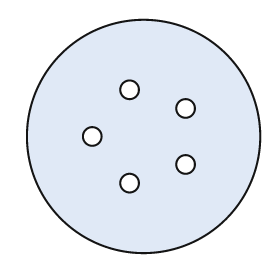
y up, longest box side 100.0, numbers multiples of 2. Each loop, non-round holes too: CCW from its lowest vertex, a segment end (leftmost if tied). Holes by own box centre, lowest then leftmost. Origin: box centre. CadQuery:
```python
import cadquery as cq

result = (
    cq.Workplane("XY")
    .moveTo(0.0, 0.0)
    .circle(50.0)
    .moveTo(-6.0, -20.0)
    .circle(4.0)
    .moveTo(18.0, -12.0)
    .circle(4.0)
    .moveTo(-22.0, 0.0)
    .circle(4.0)
    .moveTo(18.0, 12.0)
    .circle(4.0)
    .moveTo(-6.0, 20.0)
    .circle(4.0)
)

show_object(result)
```